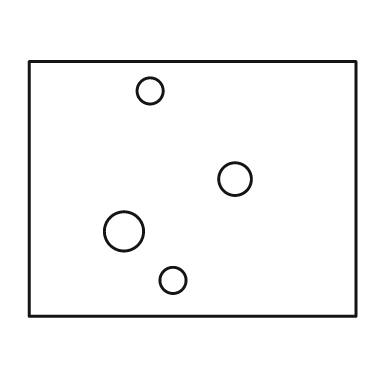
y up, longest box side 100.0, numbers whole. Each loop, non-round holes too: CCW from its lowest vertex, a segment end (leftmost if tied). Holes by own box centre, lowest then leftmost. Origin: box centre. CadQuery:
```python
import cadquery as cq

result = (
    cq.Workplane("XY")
    .moveTo(-50.0, -39.0)
    .lineTo(50.0, -39.0)
    .lineTo(50.0, 39.0)
    .lineTo(-50.0, 39.0)
    .close()
    .moveTo(-6.0, -28.0)
    .circle(4.0)
    .moveTo(-21.0, -13.0)
    .circle(6.0)
    .moveTo(13.0, 3.0)
    .circle(5.0)
    .moveTo(-13.0, 30.0)
    .circle(4.0)
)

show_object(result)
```